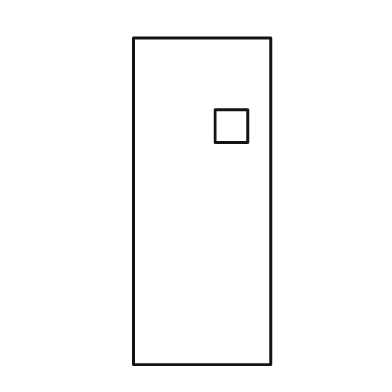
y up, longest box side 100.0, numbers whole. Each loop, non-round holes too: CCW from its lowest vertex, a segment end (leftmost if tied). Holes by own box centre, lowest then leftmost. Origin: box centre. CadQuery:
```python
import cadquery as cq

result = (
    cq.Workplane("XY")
    .moveTo(-21.0, -50.0)
    .lineTo(21.0, -50.0)
    .lineTo(21.0, 50.0)
    .lineTo(-21.0, 50.0)
    .close()
    .moveTo(4.0, 18.0)
    .lineTo(14.0, 18.0)
    .lineTo(14.0, 28.0)
    .lineTo(4.0, 28.0)
    .close()
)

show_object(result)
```